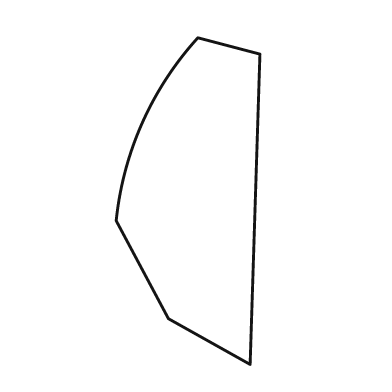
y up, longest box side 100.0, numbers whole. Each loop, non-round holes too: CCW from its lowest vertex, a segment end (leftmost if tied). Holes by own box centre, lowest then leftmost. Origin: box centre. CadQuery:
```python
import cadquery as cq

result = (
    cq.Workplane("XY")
    .moveTo(19.0, -50.0)
    .lineTo(22.0, 45.0)
    .lineTo(3.0, 50.0)
    .threePointArc((-14.0, 24.0), (-22.0, -6.0))
    .lineTo(-6.0, -36.0)
    .close()
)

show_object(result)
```